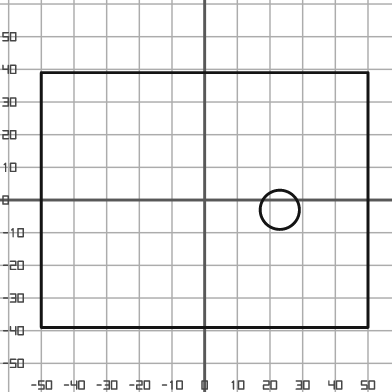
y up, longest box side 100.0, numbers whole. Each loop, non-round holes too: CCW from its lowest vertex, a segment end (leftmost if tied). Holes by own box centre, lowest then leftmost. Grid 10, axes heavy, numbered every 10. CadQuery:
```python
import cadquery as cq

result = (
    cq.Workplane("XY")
    .moveTo(-50.0, -39.0)
    .lineTo(50.0, -39.0)
    .lineTo(50.0, 39.0)
    .lineTo(-50.0, 39.0)
    .close()
    .moveTo(23.0, -3.0)
    .circle(6.0)
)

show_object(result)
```